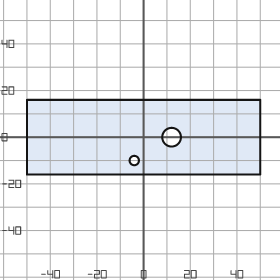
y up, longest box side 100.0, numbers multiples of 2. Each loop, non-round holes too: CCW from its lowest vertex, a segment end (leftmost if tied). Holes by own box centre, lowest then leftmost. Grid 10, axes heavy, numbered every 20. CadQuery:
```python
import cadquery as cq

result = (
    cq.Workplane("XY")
    .moveTo(-50.0, -16.0)
    .lineTo(50.0, -16.0)
    .lineTo(50.0, 16.0)
    .lineTo(-50.0, 16.0)
    .close()
    .moveTo(-4.0, -10.0)
    .circle(2.0)
    .moveTo(12.0, 0.0)
    .circle(4.0)
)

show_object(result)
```